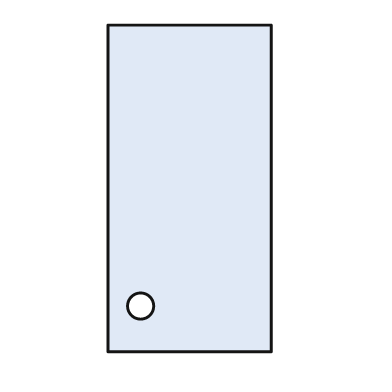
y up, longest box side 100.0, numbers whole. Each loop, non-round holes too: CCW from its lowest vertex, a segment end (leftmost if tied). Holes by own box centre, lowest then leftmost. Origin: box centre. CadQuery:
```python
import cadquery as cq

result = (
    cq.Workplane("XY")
    .moveTo(-25.0, -50.0)
    .lineTo(25.0, -50.0)
    .lineTo(25.0, 50.0)
    .lineTo(-25.0, 50.0)
    .close()
    .moveTo(-15.0, -36.0)
    .circle(4.0)
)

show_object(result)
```